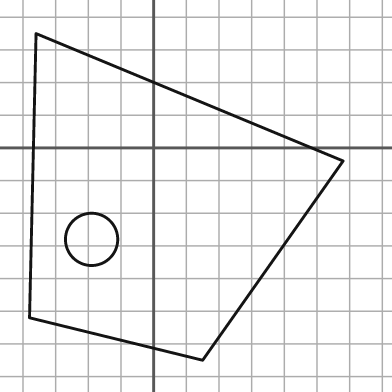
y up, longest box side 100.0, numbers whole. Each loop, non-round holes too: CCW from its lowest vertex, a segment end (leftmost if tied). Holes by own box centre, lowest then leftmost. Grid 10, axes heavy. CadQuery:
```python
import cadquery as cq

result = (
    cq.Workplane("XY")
    .moveTo(15.0, -65.0)
    .lineTo(58.0, -4.0)
    .lineTo(-36.0, 35.0)
    .lineTo(-38.0, -52.0)
    .close()
    .moveTo(-19.0, -28.0)
    .circle(8.0)
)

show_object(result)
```